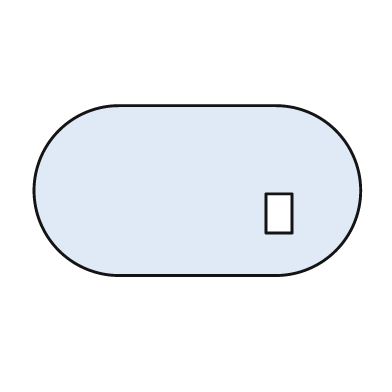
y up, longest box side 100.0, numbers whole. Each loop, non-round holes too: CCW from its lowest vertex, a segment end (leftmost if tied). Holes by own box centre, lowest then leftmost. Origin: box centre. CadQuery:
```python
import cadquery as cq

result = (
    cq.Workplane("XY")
    .moveTo(-24.0, -26.0)
    .lineTo(24.0, -26.0)
    .threePointArc((50.0, 0.0), (24.0, 26.0))
    .lineTo(-24.0, 26.0)
    .threePointArc((-50.0, 0.0), (-24.0, -26.0))
    .close()
    .moveTo(21.0, -13.0)
    .lineTo(29.0, -13.0)
    .lineTo(29.0, -1.0)
    .lineTo(21.0, -1.0)
    .close()
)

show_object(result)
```